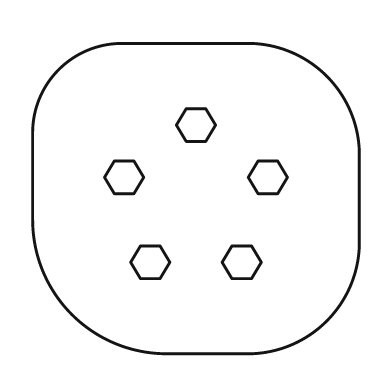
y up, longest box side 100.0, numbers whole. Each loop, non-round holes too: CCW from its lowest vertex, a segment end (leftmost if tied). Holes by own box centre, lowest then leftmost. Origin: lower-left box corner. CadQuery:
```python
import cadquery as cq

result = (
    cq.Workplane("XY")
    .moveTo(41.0, 0.0)
    .lineTo(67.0, 0.0)
    .threePointArc((90.0, 10.0), (100.0, 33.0))
    .lineTo(100.0, 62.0)
    .threePointArc((90.0, 85.0), (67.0, 95.0))
    .lineTo(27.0, 95.0)
    .threePointArc((8.0, 87.0), (0.0, 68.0))
    .lineTo(0.0, 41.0)
    .threePointArc((12.0, 12.0), (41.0, 0.0))
    .close()
    .moveTo(33.0, 23.0)
    .lineTo(39.0, 23.0)
    .lineTo(42.0, 28.0)
    .lineTo(39.0, 33.0)
    .lineTo(33.0, 33.0)
    .lineTo(30.0, 28.0)
    .close()
    .moveTo(61.0, 23.0)
    .lineTo(67.0, 23.0)
    .lineTo(70.0, 28.0)
    .lineTo(67.0, 33.0)
    .lineTo(61.0, 33.0)
    .lineTo(58.0, 28.0)
    .close()
    .moveTo(25.0, 49.0)
    .lineTo(31.0, 49.0)
    .lineTo(34.0, 54.0)
    .lineTo(31.0, 59.0)
    .lineTo(25.0, 59.0)
    .lineTo(22.0, 54.0)
    .close()
    .moveTo(69.0, 49.0)
    .lineTo(75.0, 49.0)
    .lineTo(78.0, 54.0)
    .lineTo(75.0, 59.0)
    .lineTo(69.0, 59.0)
    .lineTo(66.0, 54.0)
    .close()
    .moveTo(47.0, 65.0)
    .lineTo(53.0, 65.0)
    .lineTo(56.0, 70.0)
    .lineTo(53.0, 75.0)
    .lineTo(47.0, 75.0)
    .lineTo(44.0, 70.0)
    .close()
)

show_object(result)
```